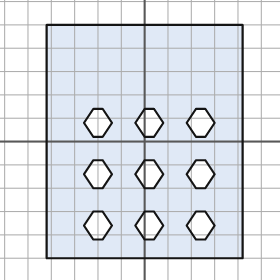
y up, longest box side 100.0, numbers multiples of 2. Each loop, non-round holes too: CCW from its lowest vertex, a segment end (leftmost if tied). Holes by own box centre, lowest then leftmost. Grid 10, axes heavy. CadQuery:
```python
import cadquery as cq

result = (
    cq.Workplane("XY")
    .moveTo(-42.0, -50.0)
    .lineTo(42.0, -50.0)
    .lineTo(42.0, 50.0)
    .lineTo(-42.0, 50.0)
    .close()
    .moveTo(-22.0, -42.0)
    .lineTo(-18.0, -42.0)
    .lineTo(-14.0, -36.0)
    .lineTo(-18.0, -30.0)
    .lineTo(-22.0, -30.0)
    .lineTo(-26.0, -36.0)
    .close()
    .moveTo(0.0, -42.0)
    .lineTo(4.0, -42.0)
    .lineTo(8.0, -36.0)
    .lineTo(4.0, -30.0)
    .lineTo(0.0, -30.0)
    .lineTo(-4.0, -36.0)
    .close()
    .moveTo(22.0, -42.0)
    .lineTo(26.0, -42.0)
    .lineTo(30.0, -36.0)
    .lineTo(26.0, -30.0)
    .lineTo(22.0, -30.0)
    .lineTo(18.0, -36.0)
    .close()
    .moveTo(-22.0, -20.0)
    .lineTo(-18.0, -20.0)
    .lineTo(-14.0, -14.0)
    .lineTo(-18.0, -8.0)
    .lineTo(-22.0, -8.0)
    .lineTo(-26.0, -14.0)
    .close()
    .moveTo(0.0, -20.0)
    .lineTo(4.0, -20.0)
    .lineTo(8.0, -14.0)
    .lineTo(4.0, -8.0)
    .lineTo(0.0, -8.0)
    .lineTo(-4.0, -14.0)
    .close()
    .moveTo(22.0, -20.0)
    .lineTo(26.0, -20.0)
    .lineTo(30.0, -14.0)
    .lineTo(26.0, -8.0)
    .lineTo(22.0, -8.0)
    .lineTo(18.0, -14.0)
    .close()
    .moveTo(-22.0, 2.0)
    .lineTo(-18.0, 2.0)
    .lineTo(-14.0, 8.0)
    .lineTo(-18.0, 14.0)
    .lineTo(-22.0, 14.0)
    .lineTo(-26.0, 8.0)
    .close()
    .moveTo(0.0, 2.0)
    .lineTo(4.0, 2.0)
    .lineTo(8.0, 8.0)
    .lineTo(4.0, 14.0)
    .lineTo(0.0, 14.0)
    .lineTo(-4.0, 8.0)
    .close()
    .moveTo(22.0, 2.0)
    .lineTo(26.0, 2.0)
    .lineTo(30.0, 8.0)
    .lineTo(26.0, 14.0)
    .lineTo(22.0, 14.0)
    .lineTo(18.0, 8.0)
    .close()
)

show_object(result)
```